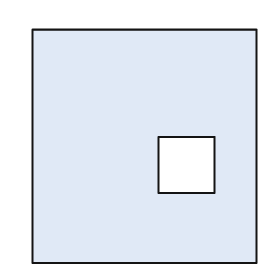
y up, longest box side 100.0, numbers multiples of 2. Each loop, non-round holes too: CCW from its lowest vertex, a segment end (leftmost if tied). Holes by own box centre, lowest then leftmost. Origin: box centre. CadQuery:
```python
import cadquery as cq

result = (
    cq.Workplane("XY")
    .moveTo(-48.0, -50.0)
    .lineTo(48.0, -50.0)
    .lineTo(48.0, 50.0)
    .lineTo(-48.0, 50.0)
    .close()
    .moveTo(6.0, -20.0)
    .lineTo(30.0, -20.0)
    .lineTo(30.0, 4.0)
    .lineTo(6.0, 4.0)
    .close()
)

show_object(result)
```